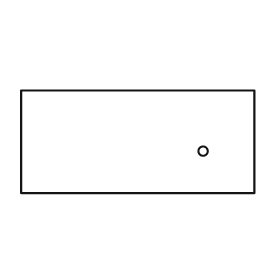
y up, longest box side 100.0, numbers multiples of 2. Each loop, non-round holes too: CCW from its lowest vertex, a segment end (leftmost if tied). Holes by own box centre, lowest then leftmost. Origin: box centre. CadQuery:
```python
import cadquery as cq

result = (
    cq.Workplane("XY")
    .moveTo(-50.0, -22.0)
    .lineTo(50.0, -22.0)
    .lineTo(50.0, 22.0)
    .lineTo(-50.0, 22.0)
    .close()
    .moveTo(28.0, -4.0)
    .circle(2.0)
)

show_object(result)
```